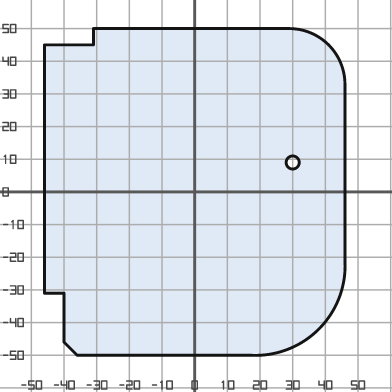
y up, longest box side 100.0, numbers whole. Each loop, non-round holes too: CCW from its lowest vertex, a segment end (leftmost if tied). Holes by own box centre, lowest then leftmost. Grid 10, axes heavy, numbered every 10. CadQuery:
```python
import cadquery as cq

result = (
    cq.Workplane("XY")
    .moveTo(-36.0, -50.0)
    .lineTo(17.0, -50.0)
    .threePointArc((38.0, -42.0), (46.0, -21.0))
    .lineTo(46.0, 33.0)
    .threePointArc((41.0, 45.0), (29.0, 50.0))
    .lineTo(-31.0, 50.0)
    .lineTo(-31.0, 45.0)
    .lineTo(-46.0, 45.0)
    .lineTo(-46.0, -31.0)
    .lineTo(-40.0, -31.0)
    .lineTo(-40.0, -46.0)
    .close()
    .moveTo(30.0, 9.0)
    .circle(2.0)
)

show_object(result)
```